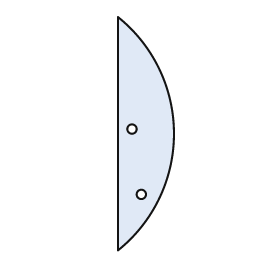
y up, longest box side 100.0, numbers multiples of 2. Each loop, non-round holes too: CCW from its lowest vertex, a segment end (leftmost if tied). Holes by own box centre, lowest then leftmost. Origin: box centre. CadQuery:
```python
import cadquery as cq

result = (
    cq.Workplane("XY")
    .moveTo(-12.0, -50.0)
    .threePointArc((12.0, 0.0), (-12.0, 50.0))
    .close()
    .moveTo(-2.0, -26.0)
    .circle(2.0)
    .moveTo(-6.0, 2.0)
    .circle(2.0)
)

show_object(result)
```